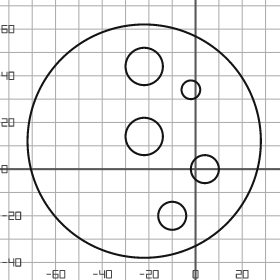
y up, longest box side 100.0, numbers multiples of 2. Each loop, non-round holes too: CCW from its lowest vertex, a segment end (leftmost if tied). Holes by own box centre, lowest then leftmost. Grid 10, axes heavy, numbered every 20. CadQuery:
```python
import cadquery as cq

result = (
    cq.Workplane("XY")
    .moveTo(-22.0, 12.0)
    .circle(50.0)
    .moveTo(-10.0, -20.0)
    .circle(6.0)
    .moveTo(4.0, 0.0)
    .circle(6.0)
    .moveTo(-22.0, 14.0)
    .circle(8.0)
    .moveTo(-2.0, 34.0)
    .circle(4.0)
    .moveTo(-22.0, 44.0)
    .circle(8.0)
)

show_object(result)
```